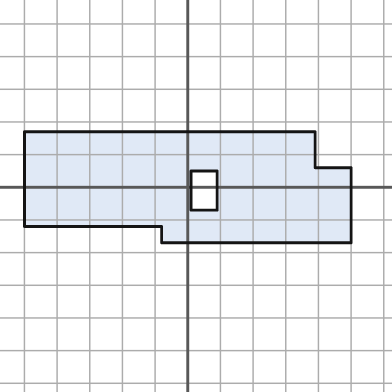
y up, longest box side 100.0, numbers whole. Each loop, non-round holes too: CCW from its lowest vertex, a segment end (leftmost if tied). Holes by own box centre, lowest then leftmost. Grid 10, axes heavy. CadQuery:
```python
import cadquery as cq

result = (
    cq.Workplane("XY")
    .moveTo(-8.0, -17.0)
    .lineTo(50.0, -17.0)
    .lineTo(50.0, 6.0)
    .lineTo(39.0, 6.0)
    .lineTo(39.0, 17.0)
    .lineTo(-50.0, 17.0)
    .lineTo(-50.0, -12.0)
    .lineTo(-8.0, -12.0)
    .close()
    .moveTo(1.0, -7.0)
    .lineTo(9.0, -7.0)
    .lineTo(9.0, 5.0)
    .lineTo(1.0, 5.0)
    .close()
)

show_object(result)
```